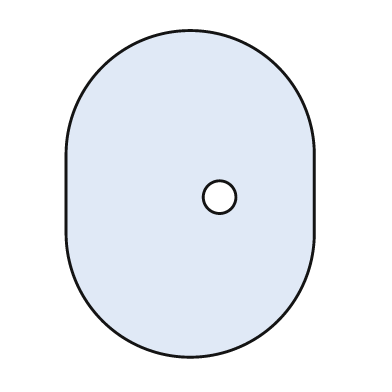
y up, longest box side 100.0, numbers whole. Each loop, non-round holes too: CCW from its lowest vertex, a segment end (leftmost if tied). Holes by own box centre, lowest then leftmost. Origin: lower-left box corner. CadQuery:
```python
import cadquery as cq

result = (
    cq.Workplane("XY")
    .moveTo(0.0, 38.0)
    .threePointArc((38.0, 0.0), (76.0, 38.0))
    .lineTo(76.0, 62.0)
    .threePointArc((38.0, 100.0), (0.0, 62.0))
    .close()
    .moveTo(47.0, 49.0)
    .circle(5.0)
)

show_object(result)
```